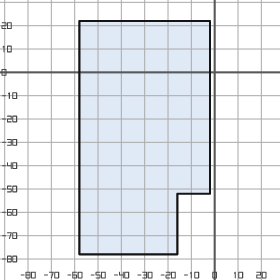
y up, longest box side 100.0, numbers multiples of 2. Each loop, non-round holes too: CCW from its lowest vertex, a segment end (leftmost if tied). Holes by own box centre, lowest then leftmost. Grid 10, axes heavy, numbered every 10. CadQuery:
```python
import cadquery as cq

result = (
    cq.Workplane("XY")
    .moveTo(-58.0, -78.0)
    .lineTo(-16.0, -78.0)
    .lineTo(-16.0, -52.0)
    .lineTo(-2.0, -52.0)
    .lineTo(-2.0, 22.0)
    .lineTo(-58.0, 22.0)
    .close()
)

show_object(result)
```